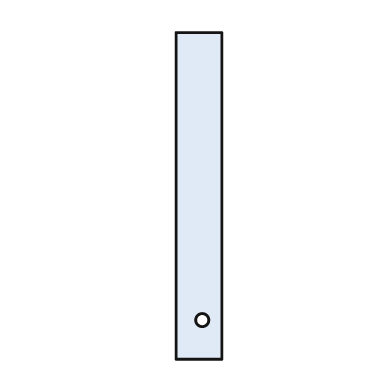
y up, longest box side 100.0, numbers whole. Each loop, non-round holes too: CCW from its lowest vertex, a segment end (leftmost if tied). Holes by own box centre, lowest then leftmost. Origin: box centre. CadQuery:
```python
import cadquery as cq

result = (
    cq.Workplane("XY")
    .moveTo(-7.0, -50.0)
    .lineTo(7.0, -50.0)
    .lineTo(7.0, 50.0)
    .lineTo(-7.0, 50.0)
    .close()
    .moveTo(1.0, -38.0)
    .circle(2.0)
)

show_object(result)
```